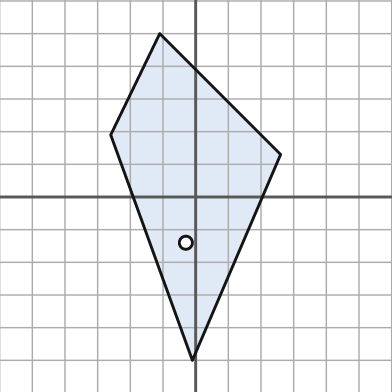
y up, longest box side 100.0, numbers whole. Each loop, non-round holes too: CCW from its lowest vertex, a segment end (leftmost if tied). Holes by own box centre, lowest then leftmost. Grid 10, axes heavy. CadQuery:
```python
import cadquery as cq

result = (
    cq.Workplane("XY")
    .moveTo(-1.0, -50.0)
    .lineTo(26.0, 13.0)
    .lineTo(-11.0, 50.0)
    .lineTo(-26.0, 19.0)
    .close()
    .moveTo(-3.0, -14.0)
    .circle(2.0)
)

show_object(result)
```